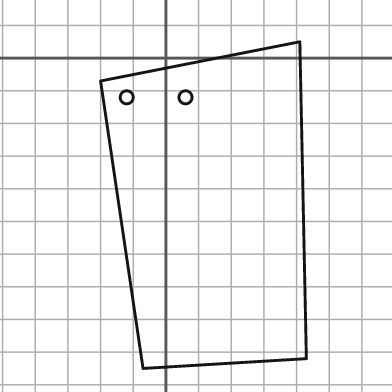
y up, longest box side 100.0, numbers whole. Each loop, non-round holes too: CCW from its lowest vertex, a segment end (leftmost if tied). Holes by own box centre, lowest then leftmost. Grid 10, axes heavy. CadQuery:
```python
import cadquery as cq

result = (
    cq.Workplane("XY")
    .moveTo(-7.0, -95.0)
    .lineTo(43.0, -92.0)
    .lineTo(41.0, 5.0)
    .lineTo(-20.0, -7.0)
    .close()
    .moveTo(-12.0, -12.0)
    .circle(2.0)
    .moveTo(6.0, -12.0)
    .circle(2.0)
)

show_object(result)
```